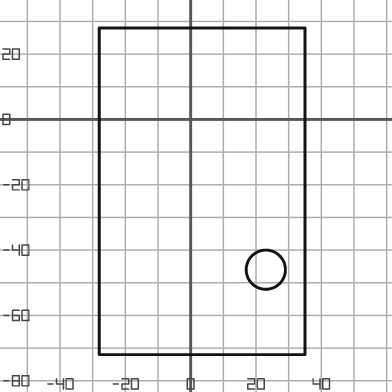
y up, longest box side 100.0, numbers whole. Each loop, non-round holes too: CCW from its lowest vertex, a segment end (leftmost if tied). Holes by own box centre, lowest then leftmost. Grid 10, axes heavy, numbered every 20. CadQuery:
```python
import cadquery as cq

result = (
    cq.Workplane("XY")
    .moveTo(-28.0, -72.0)
    .lineTo(35.0, -72.0)
    .lineTo(35.0, 28.0)
    .lineTo(-28.0, 28.0)
    .close()
    .moveTo(23.0, -46.0)
    .circle(6.0)
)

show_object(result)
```